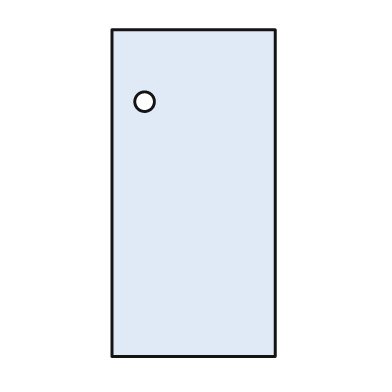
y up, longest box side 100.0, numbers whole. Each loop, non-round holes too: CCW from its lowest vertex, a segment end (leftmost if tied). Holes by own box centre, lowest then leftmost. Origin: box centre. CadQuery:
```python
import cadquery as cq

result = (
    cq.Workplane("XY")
    .moveTo(-25.0, -50.0)
    .lineTo(25.0, -50.0)
    .lineTo(25.0, 50.0)
    .lineTo(-25.0, 50.0)
    .close()
    .moveTo(-15.0, 28.0)
    .circle(3.0)
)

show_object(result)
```